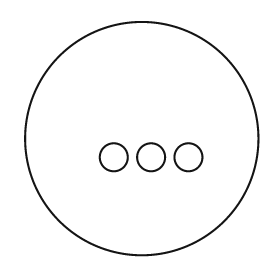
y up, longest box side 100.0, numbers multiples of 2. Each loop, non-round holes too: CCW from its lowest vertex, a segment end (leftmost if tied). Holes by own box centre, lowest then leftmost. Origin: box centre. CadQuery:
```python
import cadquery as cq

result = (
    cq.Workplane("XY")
    .moveTo(0.0, 0.0)
    .circle(50.0)
    .moveTo(-12.0, -8.0)
    .circle(6.0)
    .moveTo(4.0, -8.0)
    .circle(6.0)
    .moveTo(20.0, -8.0)
    .circle(6.0)
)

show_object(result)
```